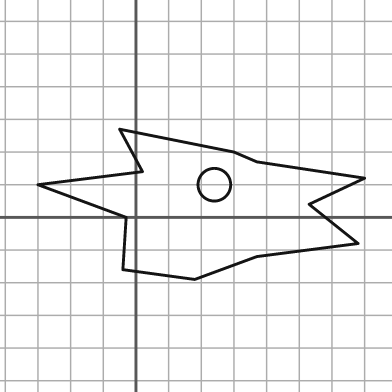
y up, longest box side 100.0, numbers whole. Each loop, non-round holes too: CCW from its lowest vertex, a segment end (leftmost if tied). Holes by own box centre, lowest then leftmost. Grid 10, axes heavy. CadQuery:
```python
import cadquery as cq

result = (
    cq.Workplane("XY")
    .moveTo(18.0, -19.0)
    .lineTo(37.0, -12.0)
    .lineTo(68.0, -8.0)
    .lineTo(53.0, 4.0)
    .lineTo(70.0, 12.0)
    .lineTo(37.0, 17.0)
    .lineTo(30.0, 20.0)
    .lineTo(-5.0, 27.0)
    .lineTo(2.0, 14.0)
    .lineTo(-30.0, 10.0)
    .lineTo(-3.0, 0.0)
    .lineTo(-4.0, -16.0)
    .close()
    .moveTo(24.0, 10.0)
    .circle(5.0)
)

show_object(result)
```